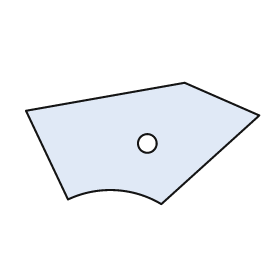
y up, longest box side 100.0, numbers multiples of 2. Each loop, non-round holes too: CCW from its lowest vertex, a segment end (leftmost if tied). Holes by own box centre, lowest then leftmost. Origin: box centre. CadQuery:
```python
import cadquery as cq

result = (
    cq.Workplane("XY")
    .moveTo(8.0, -26.0)
    .lineTo(50.0, 12.0)
    .lineTo(18.0, 26.0)
    .lineTo(-50.0, 14.0)
    .lineTo(-32.0, -24.0)
    .threePointArc((-12.0, -20.0), (8.0, -26.0))
    .close()
    .moveTo(2.0, 0.0)
    .circle(4.0)
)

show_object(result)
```